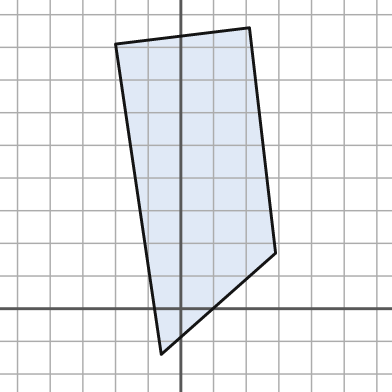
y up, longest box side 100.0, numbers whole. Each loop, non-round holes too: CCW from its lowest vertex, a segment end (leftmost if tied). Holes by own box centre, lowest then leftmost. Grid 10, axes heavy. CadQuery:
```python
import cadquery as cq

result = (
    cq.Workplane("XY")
    .moveTo(-6.0, -14.0)
    .lineTo(29.0, 17.0)
    .lineTo(21.0, 86.0)
    .lineTo(-20.0, 81.0)
    .close()
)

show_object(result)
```